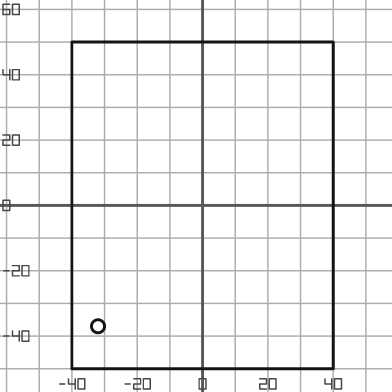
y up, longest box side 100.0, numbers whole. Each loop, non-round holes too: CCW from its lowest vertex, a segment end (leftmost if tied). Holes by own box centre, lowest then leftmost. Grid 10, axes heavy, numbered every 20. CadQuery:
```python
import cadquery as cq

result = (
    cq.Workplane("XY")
    .moveTo(-40.0, -50.0)
    .lineTo(40.0, -50.0)
    .lineTo(40.0, 50.0)
    .lineTo(-40.0, 50.0)
    .close()
    .moveTo(-32.0, -37.0)
    .circle(2.0)
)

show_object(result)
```